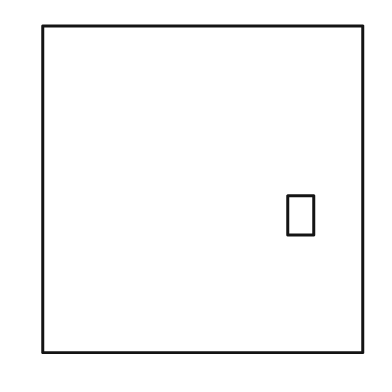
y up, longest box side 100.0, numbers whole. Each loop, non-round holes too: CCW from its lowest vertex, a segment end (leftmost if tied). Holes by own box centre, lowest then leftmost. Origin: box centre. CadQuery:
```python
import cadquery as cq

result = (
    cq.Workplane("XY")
    .moveTo(-49.0, -50.0)
    .lineTo(49.0, -50.0)
    .lineTo(49.0, 50.0)
    .lineTo(-49.0, 50.0)
    .close()
    .moveTo(26.0, -14.0)
    .lineTo(34.0, -14.0)
    .lineTo(34.0, -2.0)
    .lineTo(26.0, -2.0)
    .close()
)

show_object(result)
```